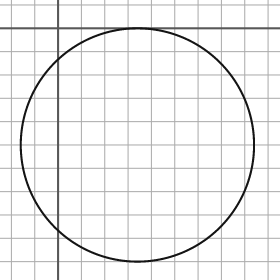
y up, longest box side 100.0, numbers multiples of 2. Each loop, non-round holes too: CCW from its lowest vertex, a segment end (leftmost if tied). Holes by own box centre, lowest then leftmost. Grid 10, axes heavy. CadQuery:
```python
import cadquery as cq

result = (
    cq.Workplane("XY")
    .moveTo(34.0, -50.0)
    .circle(50.0)
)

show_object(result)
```